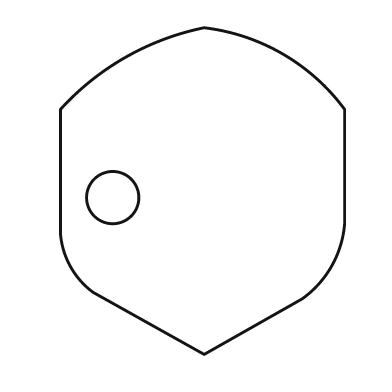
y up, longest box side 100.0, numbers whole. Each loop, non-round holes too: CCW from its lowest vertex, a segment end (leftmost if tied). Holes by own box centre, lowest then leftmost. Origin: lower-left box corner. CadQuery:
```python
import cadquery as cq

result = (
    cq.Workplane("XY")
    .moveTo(44.0, 0.0)
    .lineTo(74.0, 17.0)
    .threePointArc((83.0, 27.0), (87.0, 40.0))
    .lineTo(87.0, 75.0)
    .threePointArc((68.0, 92.0), (44.0, 100.0))
    .threePointArc((20.0, 91.0), (0.0, 75.0))
    .lineTo(0.0, 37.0)
    .threePointArc((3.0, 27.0), (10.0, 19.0))
    .close()
    .moveTo(16.0, 48.0)
    .circle(8.0)
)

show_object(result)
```